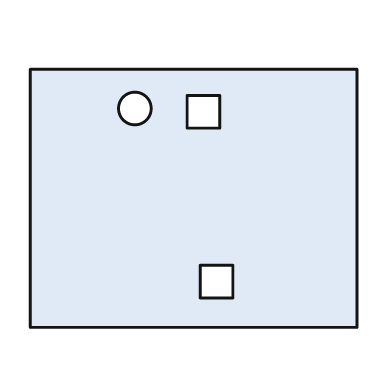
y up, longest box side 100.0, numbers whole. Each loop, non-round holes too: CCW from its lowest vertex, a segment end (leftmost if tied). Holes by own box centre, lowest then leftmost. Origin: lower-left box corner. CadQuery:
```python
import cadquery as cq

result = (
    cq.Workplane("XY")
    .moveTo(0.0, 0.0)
    .lineTo(100.0, 0.0)
    .lineTo(100.0, 79.0)
    .lineTo(0.0, 79.0)
    .close()
    .moveTo(52.0, 9.0)
    .lineTo(62.0, 9.0)
    .lineTo(62.0, 19.0)
    .lineTo(52.0, 19.0)
    .close()
    .moveTo(48.0, 61.0)
    .lineTo(58.0, 61.0)
    .lineTo(58.0, 71.0)
    .lineTo(48.0, 71.0)
    .close()
    .moveTo(32.0, 67.0)
    .circle(5.0)
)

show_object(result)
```